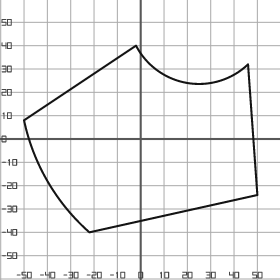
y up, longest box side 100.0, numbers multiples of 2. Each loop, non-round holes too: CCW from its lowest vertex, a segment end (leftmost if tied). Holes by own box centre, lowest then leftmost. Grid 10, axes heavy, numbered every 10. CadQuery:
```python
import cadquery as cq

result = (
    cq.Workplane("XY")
    .moveTo(-22.0, -40.0)
    .lineTo(50.0, -24.0)
    .lineTo(46.0, 32.0)
    .threePointArc((20.0, 24.0), (-2.0, 40.0))
    .lineTo(-50.0, 8.0)
    .threePointArc((-40.0, -18.0), (-22.0, -40.0))
    .close()
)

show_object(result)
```